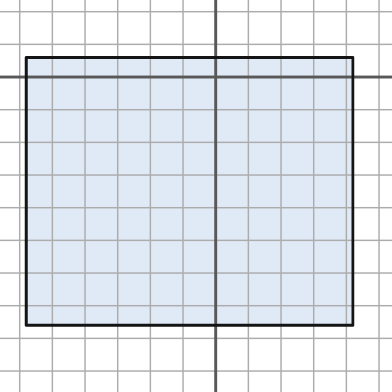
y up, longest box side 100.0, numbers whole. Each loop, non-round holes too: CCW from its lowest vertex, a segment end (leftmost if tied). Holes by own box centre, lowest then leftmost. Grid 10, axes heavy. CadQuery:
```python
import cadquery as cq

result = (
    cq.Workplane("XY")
    .moveTo(-58.0, -76.0)
    .lineTo(42.0, -76.0)
    .lineTo(42.0, 6.0)
    .lineTo(-58.0, 6.0)
    .close()
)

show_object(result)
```